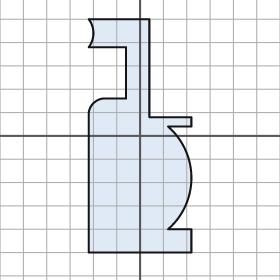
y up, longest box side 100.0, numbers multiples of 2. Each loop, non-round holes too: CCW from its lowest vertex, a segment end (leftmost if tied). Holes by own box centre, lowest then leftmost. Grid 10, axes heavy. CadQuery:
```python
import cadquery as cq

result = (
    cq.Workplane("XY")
    .moveTo(-22.0, -50.0)
    .lineTo(22.0, -50.0)
    .lineTo(22.0, -40.0)
    .lineTo(12.0, -40.0)
    .threePointArc((22.0, -18.0), (12.0, 4.0))
    .lineTo(22.0, 4.0)
    .lineTo(22.0, 8.0)
    .lineTo(4.0, 8.0)
    .lineTo(4.0, 50.0)
    .lineTo(-22.0, 50.0)
    .threePointArc((-20.0, 44.0), (-22.0, 38.0))
    .lineTo(-6.0, 38.0)
    .lineTo(-6.0, 16.0)
    .lineTo(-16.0, 16.0)
    .threePointArc((-20.0, 14.0), (-22.0, 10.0))
    .close()
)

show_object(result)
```